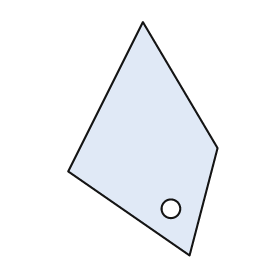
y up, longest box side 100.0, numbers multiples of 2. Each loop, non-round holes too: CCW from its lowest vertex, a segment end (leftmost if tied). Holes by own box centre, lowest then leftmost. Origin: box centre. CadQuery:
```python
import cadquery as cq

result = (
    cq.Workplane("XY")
    .moveTo(20.0, -50.0)
    .lineTo(32.0, -4.0)
    .lineTo(0.0, 50.0)
    .lineTo(-32.0, -14.0)
    .close()
    .moveTo(12.0, -30.0)
    .circle(4.0)
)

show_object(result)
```